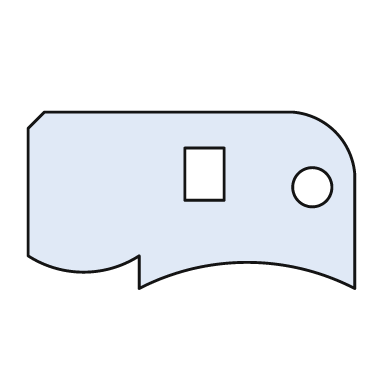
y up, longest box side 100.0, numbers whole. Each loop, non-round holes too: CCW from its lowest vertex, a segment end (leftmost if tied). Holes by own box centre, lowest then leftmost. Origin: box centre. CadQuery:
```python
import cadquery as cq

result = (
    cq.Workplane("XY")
    .moveTo(-16.0, -27.0)
    .threePointArc((17.0, -19.0), (50.0, -27.0))
    .lineTo(50.0, 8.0)
    .threePointArc((44.0, 21.0), (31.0, 27.0))
    .lineTo(-45.0, 27.0)
    .lineTo(-50.0, 22.0)
    .lineTo(-50.0, -17.0)
    .threePointArc((-33.0, -22.0), (-16.0, -17.0))
    .close()
    .moveTo(37.0, 4.0)
    .circle(6.0)
    .moveTo(-2.0, 0.0)
    .lineTo(10.0, 0.0)
    .lineTo(10.0, 16.0)
    .lineTo(-2.0, 16.0)
    .close()
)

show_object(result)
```